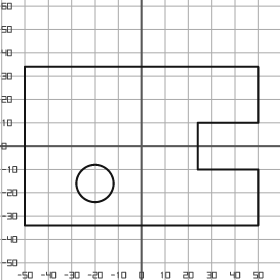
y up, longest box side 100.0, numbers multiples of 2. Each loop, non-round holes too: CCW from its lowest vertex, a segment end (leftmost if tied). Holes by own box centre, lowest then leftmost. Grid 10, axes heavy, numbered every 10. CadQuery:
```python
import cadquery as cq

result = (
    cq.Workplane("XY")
    .moveTo(-50.0, -34.0)
    .lineTo(50.0, -34.0)
    .lineTo(50.0, -10.0)
    .lineTo(24.0, -10.0)
    .lineTo(24.0, 10.0)
    .lineTo(50.0, 10.0)
    .lineTo(50.0, 34.0)
    .lineTo(-50.0, 34.0)
    .close()
    .moveTo(-20.0, -16.0)
    .circle(8.0)
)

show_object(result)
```